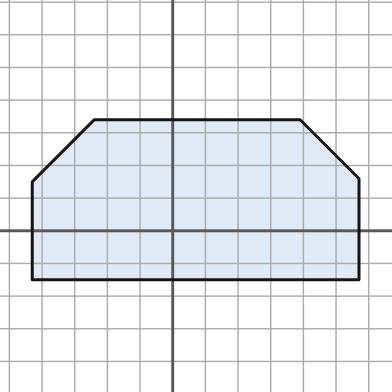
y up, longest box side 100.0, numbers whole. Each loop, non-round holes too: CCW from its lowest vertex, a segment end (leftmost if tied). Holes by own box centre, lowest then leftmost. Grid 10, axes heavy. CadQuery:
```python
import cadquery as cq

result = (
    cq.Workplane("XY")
    .moveTo(-43.0, -15.0)
    .lineTo(57.0, -15.0)
    .lineTo(57.0, 16.0)
    .lineTo(39.0, 34.0)
    .lineTo(-24.0, 34.0)
    .lineTo(-43.0, 15.0)
    .close()
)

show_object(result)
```